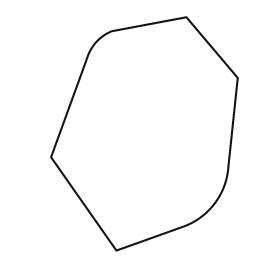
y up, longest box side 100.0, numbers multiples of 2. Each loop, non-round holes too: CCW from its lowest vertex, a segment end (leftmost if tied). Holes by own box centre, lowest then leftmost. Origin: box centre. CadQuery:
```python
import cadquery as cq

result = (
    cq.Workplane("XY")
    .moveTo(-12.0, -50.0)
    .lineTo(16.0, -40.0)
    .threePointArc((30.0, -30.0), (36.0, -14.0))
    .lineTo(40.0, 24.0)
    .lineTo(18.0, 50.0)
    .lineTo(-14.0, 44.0)
    .threePointArc((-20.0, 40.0), (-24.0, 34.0))
    .lineTo(-40.0, -10.0)
    .close()
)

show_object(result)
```